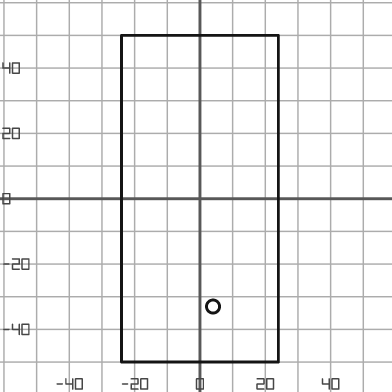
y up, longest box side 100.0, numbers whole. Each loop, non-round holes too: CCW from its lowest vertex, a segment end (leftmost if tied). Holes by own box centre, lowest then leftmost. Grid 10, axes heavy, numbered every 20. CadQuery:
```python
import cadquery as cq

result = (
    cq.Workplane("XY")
    .moveTo(-24.0, -50.0)
    .lineTo(24.0, -50.0)
    .lineTo(24.0, 50.0)
    .lineTo(-24.0, 50.0)
    .close()
    .moveTo(4.0, -33.0)
    .circle(2.0)
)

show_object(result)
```